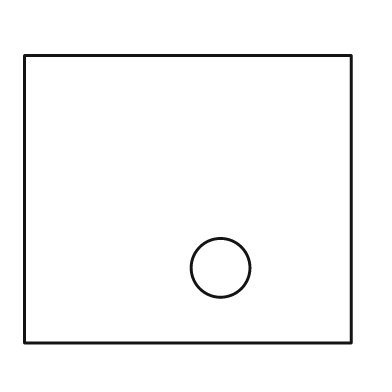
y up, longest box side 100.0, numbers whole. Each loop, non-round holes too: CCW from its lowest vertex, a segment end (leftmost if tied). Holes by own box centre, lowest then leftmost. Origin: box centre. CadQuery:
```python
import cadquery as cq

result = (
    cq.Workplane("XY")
    .moveTo(-50.0, -44.0)
    .lineTo(50.0, -44.0)
    .lineTo(50.0, 44.0)
    .lineTo(-50.0, 44.0)
    .close()
    .moveTo(10.0, -21.0)
    .circle(9.0)
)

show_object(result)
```